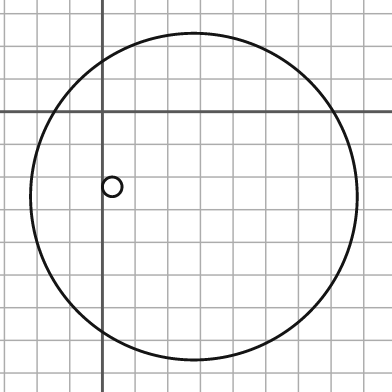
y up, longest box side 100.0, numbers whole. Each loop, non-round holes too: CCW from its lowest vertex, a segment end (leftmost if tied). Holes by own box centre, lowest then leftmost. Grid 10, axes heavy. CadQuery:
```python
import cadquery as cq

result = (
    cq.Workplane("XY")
    .moveTo(28.0, -26.0)
    .circle(50.0)
    .moveTo(3.0, -23.0)
    .circle(3.0)
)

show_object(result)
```